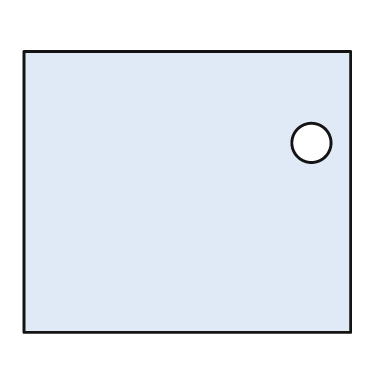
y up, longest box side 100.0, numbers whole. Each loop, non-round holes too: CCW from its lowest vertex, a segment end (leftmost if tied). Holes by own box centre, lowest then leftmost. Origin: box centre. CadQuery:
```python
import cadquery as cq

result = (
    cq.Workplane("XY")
    .moveTo(-50.0, -43.0)
    .lineTo(50.0, -43.0)
    .lineTo(50.0, 43.0)
    .lineTo(-50.0, 43.0)
    .close()
    .moveTo(38.0, 15.0)
    .circle(6.0)
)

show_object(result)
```